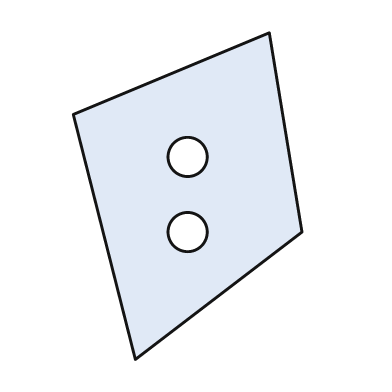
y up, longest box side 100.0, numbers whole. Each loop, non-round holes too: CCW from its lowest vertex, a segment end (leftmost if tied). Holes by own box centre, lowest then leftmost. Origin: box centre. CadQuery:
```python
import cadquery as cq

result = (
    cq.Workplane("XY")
    .moveTo(-16.0, -50.0)
    .lineTo(35.0, -11.0)
    .lineTo(25.0, 50.0)
    .lineTo(-35.0, 25.0)
    .close()
    .moveTo(0.0, -11.0)
    .circle(6.0)
    .moveTo(0.0, 12.0)
    .circle(6.0)
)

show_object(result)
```